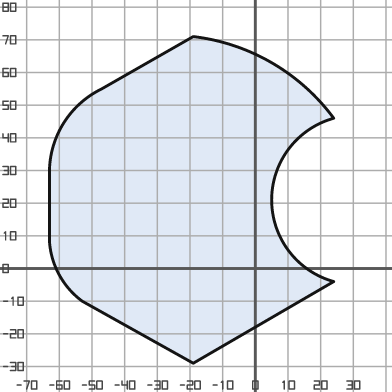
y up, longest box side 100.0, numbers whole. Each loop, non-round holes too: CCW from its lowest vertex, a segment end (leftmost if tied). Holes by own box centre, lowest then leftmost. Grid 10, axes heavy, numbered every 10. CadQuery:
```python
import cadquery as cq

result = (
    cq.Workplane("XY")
    .moveTo(-19.0, -29.0)
    .lineTo(24.0, -4.0)
    .threePointArc((5.0, 21.0), (24.0, 46.0))
    .threePointArc((5.0, 63.0), (-19.0, 71.0))
    .lineTo(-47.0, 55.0)
    .threePointArc((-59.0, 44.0), (-63.0, 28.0))
    .lineTo(-63.0, 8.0)
    .threePointArc((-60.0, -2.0), (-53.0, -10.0))
    .close()
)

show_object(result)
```